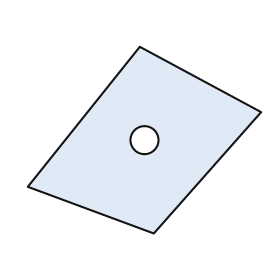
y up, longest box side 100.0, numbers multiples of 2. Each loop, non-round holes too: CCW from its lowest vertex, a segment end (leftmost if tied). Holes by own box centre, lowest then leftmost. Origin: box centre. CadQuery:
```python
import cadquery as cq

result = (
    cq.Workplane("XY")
    .moveTo(4.0, -40.0)
    .lineTo(50.0, 12.0)
    .lineTo(-2.0, 40.0)
    .lineTo(-50.0, -20.0)
    .close()
    .moveTo(0.0, 0.0)
    .circle(6.0)
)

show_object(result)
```